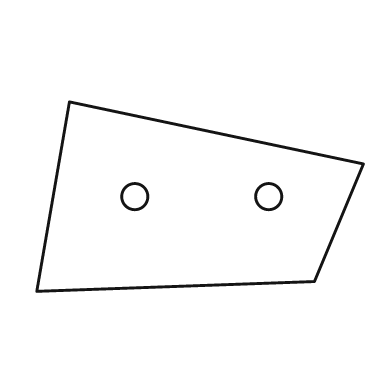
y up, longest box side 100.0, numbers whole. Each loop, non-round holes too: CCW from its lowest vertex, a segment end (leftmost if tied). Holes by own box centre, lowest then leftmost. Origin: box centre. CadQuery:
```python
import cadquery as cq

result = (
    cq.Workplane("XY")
    .moveTo(-50.0, -29.0)
    .lineTo(35.0, -26.0)
    .lineTo(50.0, 10.0)
    .lineTo(-40.0, 29.0)
    .close()
    .moveTo(-20.0, 0.0)
    .circle(4.0)
    .moveTo(21.0, 0.0)
    .circle(4.0)
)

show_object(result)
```